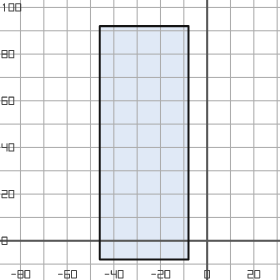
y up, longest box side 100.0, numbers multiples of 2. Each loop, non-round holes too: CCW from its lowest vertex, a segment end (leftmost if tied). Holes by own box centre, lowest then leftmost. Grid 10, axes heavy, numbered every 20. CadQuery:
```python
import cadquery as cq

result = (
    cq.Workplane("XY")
    .moveTo(-46.0, -8.0)
    .lineTo(-8.0, -8.0)
    .lineTo(-8.0, 92.0)
    .lineTo(-46.0, 92.0)
    .close()
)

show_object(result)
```